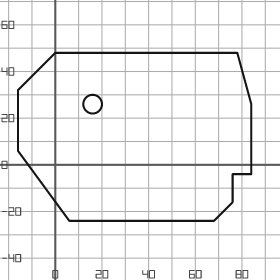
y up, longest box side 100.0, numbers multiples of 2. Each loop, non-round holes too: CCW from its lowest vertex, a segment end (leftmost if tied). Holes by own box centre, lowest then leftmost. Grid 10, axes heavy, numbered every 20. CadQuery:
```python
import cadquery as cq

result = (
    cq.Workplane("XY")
    .moveTo(6.0, -24.0)
    .lineTo(68.0, -24.0)
    .lineTo(76.0, -16.0)
    .lineTo(76.0, -4.0)
    .lineTo(84.0, -4.0)
    .lineTo(84.0, 26.0)
    .lineTo(78.0, 48.0)
    .lineTo(0.0, 48.0)
    .lineTo(-16.0, 32.0)
    .lineTo(-16.0, 6.0)
    .close()
    .moveTo(16.0, 26.0)
    .circle(4.0)
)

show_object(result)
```